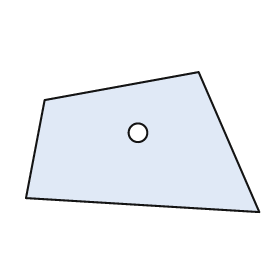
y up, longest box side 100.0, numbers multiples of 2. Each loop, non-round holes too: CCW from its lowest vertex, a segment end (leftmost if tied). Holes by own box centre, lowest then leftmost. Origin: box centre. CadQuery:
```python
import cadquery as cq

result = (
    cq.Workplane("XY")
    .moveTo(50.0, -30.0)
    .lineTo(24.0, 30.0)
    .lineTo(-42.0, 18.0)
    .lineTo(-50.0, -24.0)
    .close()
    .moveTo(-2.0, 4.0)
    .circle(4.0)
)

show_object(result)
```